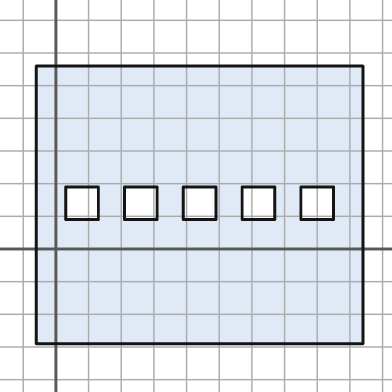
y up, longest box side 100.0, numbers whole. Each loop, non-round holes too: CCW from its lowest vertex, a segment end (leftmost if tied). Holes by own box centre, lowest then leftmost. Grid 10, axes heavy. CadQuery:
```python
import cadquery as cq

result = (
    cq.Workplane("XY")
    .moveTo(-6.0, -29.0)
    .lineTo(94.0, -29.0)
    .lineTo(94.0, 56.0)
    .lineTo(-6.0, 56.0)
    .close()
    .moveTo(3.0, 9.0)
    .lineTo(13.0, 9.0)
    .lineTo(13.0, 19.0)
    .lineTo(3.0, 19.0)
    .close()
    .moveTo(21.0, 9.0)
    .lineTo(31.0, 9.0)
    .lineTo(31.0, 19.0)
    .lineTo(21.0, 19.0)
    .close()
    .moveTo(39.0, 9.0)
    .lineTo(49.0, 9.0)
    .lineTo(49.0, 19.0)
    .lineTo(39.0, 19.0)
    .close()
    .moveTo(57.0, 9.0)
    .lineTo(67.0, 9.0)
    .lineTo(67.0, 19.0)
    .lineTo(57.0, 19.0)
    .close()
    .moveTo(75.0, 9.0)
    .lineTo(85.0, 9.0)
    .lineTo(85.0, 19.0)
    .lineTo(75.0, 19.0)
    .close()
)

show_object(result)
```